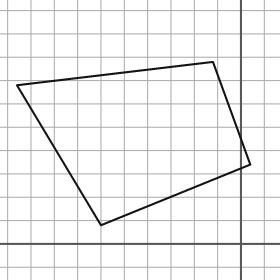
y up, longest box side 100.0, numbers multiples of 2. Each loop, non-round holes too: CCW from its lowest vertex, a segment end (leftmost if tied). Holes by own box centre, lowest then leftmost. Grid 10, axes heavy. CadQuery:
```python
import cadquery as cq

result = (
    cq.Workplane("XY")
    .moveTo(-60.0, 8.0)
    .lineTo(4.0, 34.0)
    .lineTo(-12.0, 78.0)
    .lineTo(-96.0, 68.0)
    .close()
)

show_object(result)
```